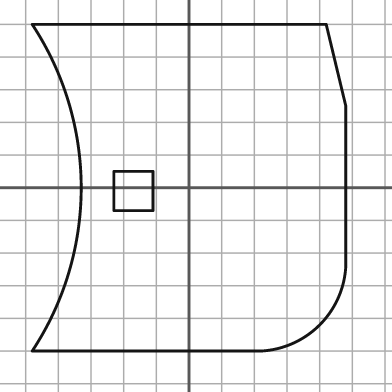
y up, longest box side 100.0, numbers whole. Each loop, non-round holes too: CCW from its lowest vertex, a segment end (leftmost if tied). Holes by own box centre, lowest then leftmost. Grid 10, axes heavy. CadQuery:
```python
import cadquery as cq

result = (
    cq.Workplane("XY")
    .moveTo(-48.0, -50.0)
    .lineTo(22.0, -50.0)
    .threePointArc((40.0, -42.0), (48.0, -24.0))
    .lineTo(48.0, 25.0)
    .lineTo(42.0, 50.0)
    .lineTo(-48.0, 50.0)
    .threePointArc((-33.0, 0.0), (-48.0, -50.0))
    .close()
    .moveTo(-23.0, -7.0)
    .lineTo(-11.0, -7.0)
    .lineTo(-11.0, 5.0)
    .lineTo(-23.0, 5.0)
    .close()
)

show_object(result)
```